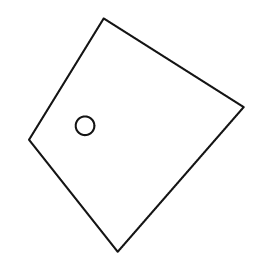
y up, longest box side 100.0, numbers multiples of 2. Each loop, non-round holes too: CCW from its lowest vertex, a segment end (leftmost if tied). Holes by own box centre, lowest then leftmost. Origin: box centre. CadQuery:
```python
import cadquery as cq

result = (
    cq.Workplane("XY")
    .moveTo(-8.0, -50.0)
    .lineTo(46.0, 12.0)
    .lineTo(-14.0, 50.0)
    .lineTo(-46.0, -2.0)
    .close()
    .moveTo(-22.0, 4.0)
    .circle(4.0)
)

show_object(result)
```